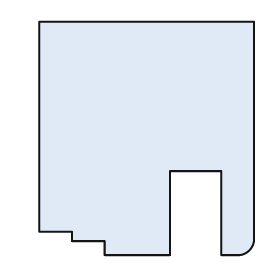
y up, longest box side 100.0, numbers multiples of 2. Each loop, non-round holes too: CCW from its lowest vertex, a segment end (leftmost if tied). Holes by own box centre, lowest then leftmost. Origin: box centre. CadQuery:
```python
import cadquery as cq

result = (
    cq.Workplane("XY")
    .moveTo(-18.0, -50.0)
    .lineTo(10.0, -50.0)
    .lineTo(10.0, -14.0)
    .lineTo(32.0, -14.0)
    .lineTo(32.0, -50.0)
    .lineTo(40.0, -50.0)
    .threePointArc((44.0, -48.0), (46.0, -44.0))
    .lineTo(46.0, 50.0)
    .lineTo(-46.0, 50.0)
    .lineTo(-46.0, -40.0)
    .lineTo(-32.0, -40.0)
    .lineTo(-32.0, -44.0)
    .lineTo(-18.0, -44.0)
    .close()
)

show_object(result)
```